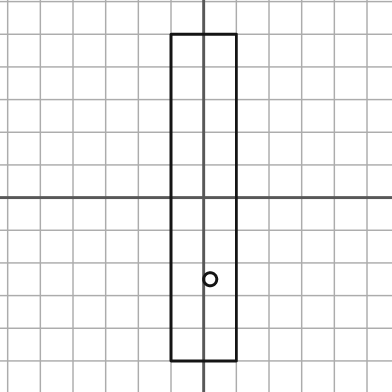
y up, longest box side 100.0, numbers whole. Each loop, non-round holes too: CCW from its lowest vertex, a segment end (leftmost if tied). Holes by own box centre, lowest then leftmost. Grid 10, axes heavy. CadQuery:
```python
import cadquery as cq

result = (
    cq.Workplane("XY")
    .moveTo(-10.0, -50.0)
    .lineTo(10.0, -50.0)
    .lineTo(10.0, 50.0)
    .lineTo(-10.0, 50.0)
    .close()
    .moveTo(2.0, -25.0)
    .circle(2.0)
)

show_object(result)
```